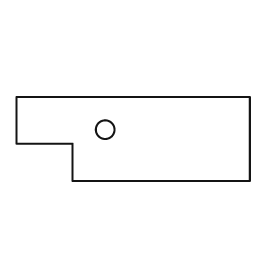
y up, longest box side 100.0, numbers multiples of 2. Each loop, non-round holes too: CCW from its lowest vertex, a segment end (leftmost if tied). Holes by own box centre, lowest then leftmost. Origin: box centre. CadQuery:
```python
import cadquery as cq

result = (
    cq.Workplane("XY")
    .moveTo(-26.0, -18.0)
    .lineTo(50.0, -18.0)
    .lineTo(50.0, 18.0)
    .lineTo(-50.0, 18.0)
    .lineTo(-50.0, -2.0)
    .lineTo(-26.0, -2.0)
    .close()
    .moveTo(-12.0, 4.0)
    .circle(4.0)
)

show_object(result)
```